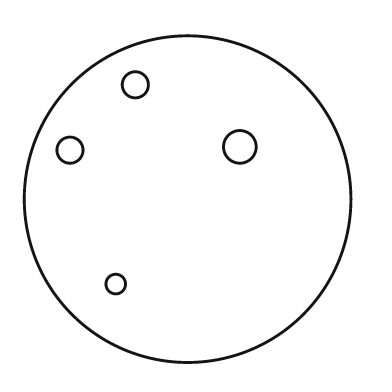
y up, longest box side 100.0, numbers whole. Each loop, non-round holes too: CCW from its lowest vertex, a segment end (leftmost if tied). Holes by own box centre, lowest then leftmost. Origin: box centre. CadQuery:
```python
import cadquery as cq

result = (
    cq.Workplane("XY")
    .moveTo(0.0, 0.0)
    .circle(50.0)
    .moveTo(-22.0, -26.0)
    .circle(3.0)
    .moveTo(-36.0, 15.0)
    .circle(4.0)
    .moveTo(16.0, 16.0)
    .circle(5.0)
    .moveTo(-16.0, 35.0)
    .circle(4.0)
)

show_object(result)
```